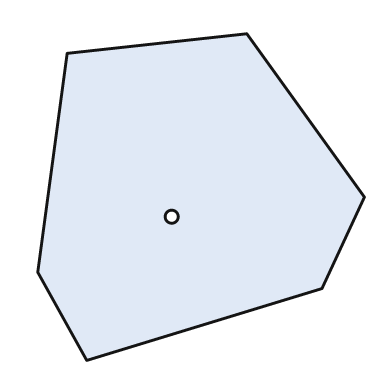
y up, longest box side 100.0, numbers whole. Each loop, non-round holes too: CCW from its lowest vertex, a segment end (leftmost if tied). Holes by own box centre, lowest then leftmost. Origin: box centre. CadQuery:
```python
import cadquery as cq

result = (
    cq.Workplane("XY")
    .moveTo(-35.0, -50.0)
    .lineTo(37.0, -28.0)
    .lineTo(50.0, 0.0)
    .lineTo(14.0, 50.0)
    .lineTo(-41.0, 44.0)
    .lineTo(-50.0, -23.0)
    .close()
    .moveTo(-9.0, -6.0)
    .circle(2.0)
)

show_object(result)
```